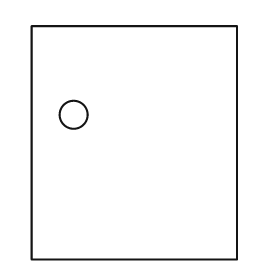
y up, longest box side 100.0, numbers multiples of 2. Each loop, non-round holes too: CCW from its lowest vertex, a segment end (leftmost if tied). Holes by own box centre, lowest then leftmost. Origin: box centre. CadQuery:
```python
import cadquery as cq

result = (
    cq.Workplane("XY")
    .moveTo(-44.0, -50.0)
    .lineTo(44.0, -50.0)
    .lineTo(44.0, 50.0)
    .lineTo(-44.0, 50.0)
    .close()
    .moveTo(-26.0, 12.0)
    .circle(6.0)
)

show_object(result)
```